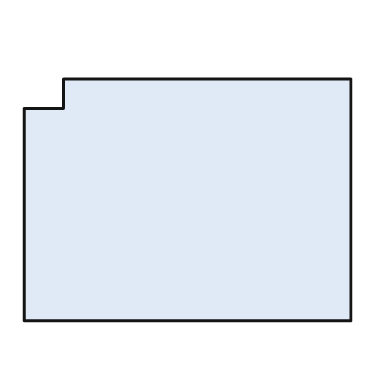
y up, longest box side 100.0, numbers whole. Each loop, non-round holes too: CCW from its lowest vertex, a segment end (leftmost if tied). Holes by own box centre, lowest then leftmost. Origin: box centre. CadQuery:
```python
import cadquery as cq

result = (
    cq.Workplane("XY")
    .moveTo(-50.0, -37.0)
    .lineTo(50.0, -37.0)
    .lineTo(50.0, 37.0)
    .lineTo(-38.0, 37.0)
    .lineTo(-38.0, 28.0)
    .lineTo(-50.0, 28.0)
    .close()
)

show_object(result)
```